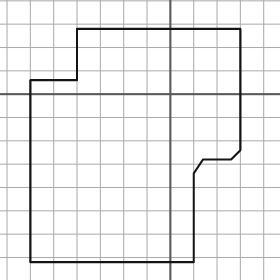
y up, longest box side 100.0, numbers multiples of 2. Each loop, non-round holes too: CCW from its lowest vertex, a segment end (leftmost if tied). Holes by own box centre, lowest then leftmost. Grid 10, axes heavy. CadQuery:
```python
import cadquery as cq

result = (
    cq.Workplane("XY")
    .moveTo(-60.0, -72.0)
    .lineTo(10.0, -72.0)
    .lineTo(10.0, -34.0)
    .lineTo(14.0, -28.0)
    .lineTo(26.0, -28.0)
    .lineTo(30.0, -24.0)
    .lineTo(30.0, 28.0)
    .lineTo(-40.0, 28.0)
    .lineTo(-40.0, 6.0)
    .lineTo(-60.0, 6.0)
    .close()
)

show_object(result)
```